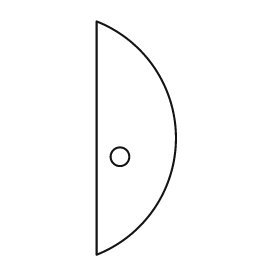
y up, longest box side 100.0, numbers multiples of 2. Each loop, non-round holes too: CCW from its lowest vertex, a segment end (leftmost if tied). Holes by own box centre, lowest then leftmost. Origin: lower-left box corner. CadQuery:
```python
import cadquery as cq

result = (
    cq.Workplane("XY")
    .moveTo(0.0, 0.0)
    .threePointArc((34.0, 50.0), (0.0, 100.0))
    .close()
    .moveTo(10.0, 42.0)
    .circle(4.0)
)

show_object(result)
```